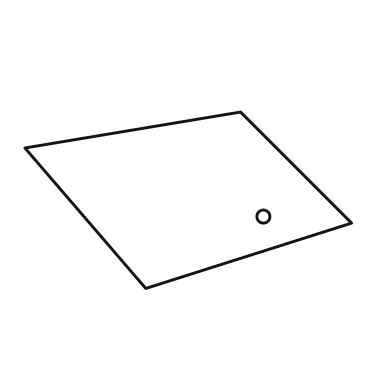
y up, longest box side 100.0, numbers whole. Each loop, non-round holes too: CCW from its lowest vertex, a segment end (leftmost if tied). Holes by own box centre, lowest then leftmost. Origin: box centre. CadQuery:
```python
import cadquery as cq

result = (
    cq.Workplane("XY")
    .moveTo(-13.0, -27.0)
    .lineTo(50.0, -7.0)
    .lineTo(16.0, 27.0)
    .lineTo(-50.0, 16.0)
    .close()
    .moveTo(23.0, -5.0)
    .circle(2.0)
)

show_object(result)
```